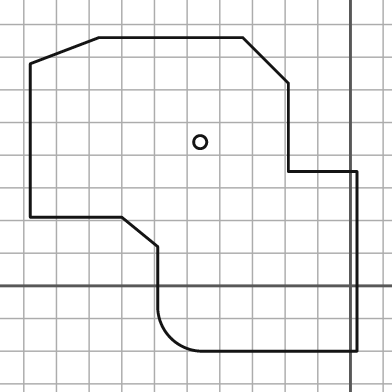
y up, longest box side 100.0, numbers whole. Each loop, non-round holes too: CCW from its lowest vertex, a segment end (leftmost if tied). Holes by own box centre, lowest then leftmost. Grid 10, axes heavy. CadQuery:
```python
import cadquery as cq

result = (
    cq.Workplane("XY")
    .moveTo(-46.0, -20.0)
    .lineTo(2.0, -20.0)
    .lineTo(2.0, 35.0)
    .lineTo(-19.0, 35.0)
    .lineTo(-19.0, 62.0)
    .lineTo(-33.0, 76.0)
    .lineTo(-77.0, 76.0)
    .lineTo(-98.0, 68.0)
    .lineTo(-98.0, 21.0)
    .lineTo(-70.0, 21.0)
    .lineTo(-59.0, 12.0)
    .lineTo(-59.0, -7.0)
    .threePointArc((-55.0, -16.0), (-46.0, -20.0))
    .close()
    .moveTo(-46.0, 44.0)
    .circle(2.0)
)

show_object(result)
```